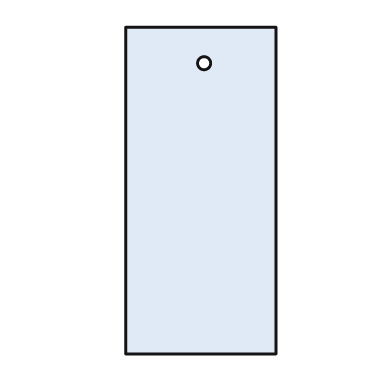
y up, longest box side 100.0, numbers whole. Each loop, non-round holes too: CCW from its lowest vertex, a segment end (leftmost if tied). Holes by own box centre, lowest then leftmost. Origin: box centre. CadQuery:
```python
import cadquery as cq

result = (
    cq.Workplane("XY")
    .moveTo(-23.0, -50.0)
    .lineTo(23.0, -50.0)
    .lineTo(23.0, 50.0)
    .lineTo(-23.0, 50.0)
    .close()
    .moveTo(1.0, 39.0)
    .circle(2.0)
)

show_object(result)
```